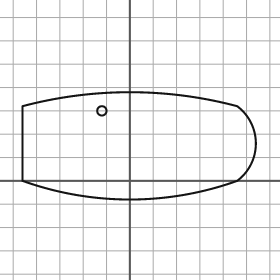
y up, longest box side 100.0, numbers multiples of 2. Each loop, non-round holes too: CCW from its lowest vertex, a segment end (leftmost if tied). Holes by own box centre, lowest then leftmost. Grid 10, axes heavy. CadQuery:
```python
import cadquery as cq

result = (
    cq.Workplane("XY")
    .moveTo(-46.0, 0.0)
    .threePointArc((0.0, -8.0), (46.0, 0.0))
    .threePointArc((54.0, 16.0), (46.0, 32.0))
    .threePointArc((0.0, 38.0), (-46.0, 32.0))
    .close()
    .moveTo(-12.0, 30.0)
    .circle(2.0)
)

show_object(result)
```